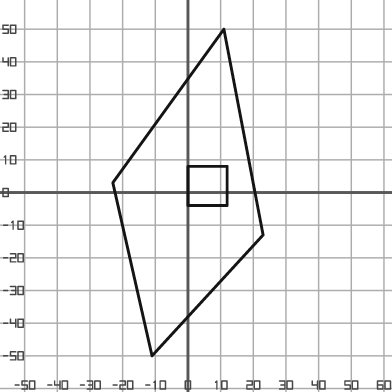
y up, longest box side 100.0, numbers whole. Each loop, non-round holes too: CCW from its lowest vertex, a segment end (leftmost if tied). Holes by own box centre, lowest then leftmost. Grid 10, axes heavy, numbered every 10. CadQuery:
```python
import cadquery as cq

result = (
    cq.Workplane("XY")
    .moveTo(-11.0, -50.0)
    .lineTo(23.0, -13.0)
    .lineTo(11.0, 50.0)
    .lineTo(-23.0, 3.0)
    .close()
    .moveTo(0.0, -4.0)
    .lineTo(12.0, -4.0)
    .lineTo(12.0, 8.0)
    .lineTo(0.0, 8.0)
    .close()
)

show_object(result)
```